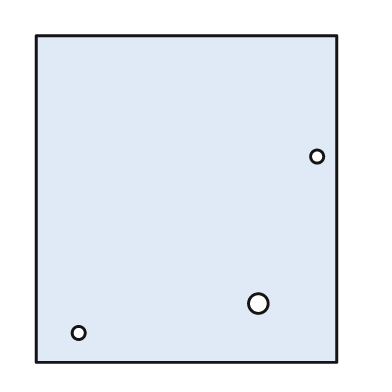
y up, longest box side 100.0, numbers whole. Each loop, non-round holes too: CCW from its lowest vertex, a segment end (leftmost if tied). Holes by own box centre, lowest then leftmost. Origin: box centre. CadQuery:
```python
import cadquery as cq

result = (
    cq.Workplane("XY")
    .moveTo(-46.0, -50.0)
    .lineTo(46.0, -50.0)
    .lineTo(46.0, 50.0)
    .lineTo(-46.0, 50.0)
    .close()
    .moveTo(-33.0, -41.0)
    .circle(2.0)
    .moveTo(22.0, -32.0)
    .circle(3.0)
    .moveTo(40.0, 13.0)
    .circle(2.0)
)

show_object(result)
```